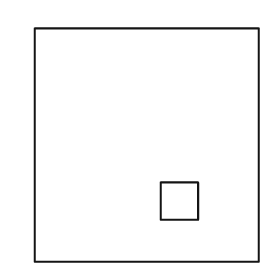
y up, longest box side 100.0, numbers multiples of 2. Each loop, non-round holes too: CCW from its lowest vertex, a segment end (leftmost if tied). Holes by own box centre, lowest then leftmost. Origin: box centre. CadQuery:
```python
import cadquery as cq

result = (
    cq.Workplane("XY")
    .moveTo(-48.0, -50.0)
    .lineTo(48.0, -50.0)
    .lineTo(48.0, 50.0)
    .lineTo(-48.0, 50.0)
    .close()
    .moveTo(6.0, -32.0)
    .lineTo(22.0, -32.0)
    .lineTo(22.0, -16.0)
    .lineTo(6.0, -16.0)
    .close()
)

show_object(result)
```